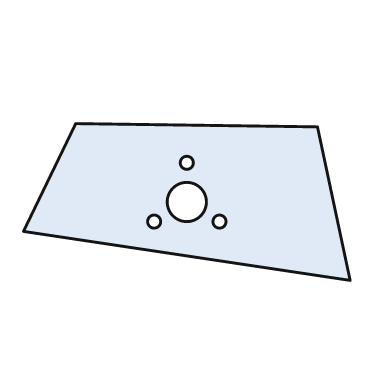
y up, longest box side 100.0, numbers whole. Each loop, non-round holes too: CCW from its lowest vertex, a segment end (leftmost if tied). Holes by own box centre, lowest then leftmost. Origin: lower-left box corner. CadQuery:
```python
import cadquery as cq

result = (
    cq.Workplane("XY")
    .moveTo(100.0, 0.0)
    .lineTo(90.0, 47.0)
    .lineTo(16.0, 48.0)
    .lineTo(0.0, 15.0)
    .close()
    .moveTo(40.0, 18.0)
    .circle(2.0)
    .moveTo(60.0, 18.0)
    .circle(2.0)
    .moveTo(50.0, 24.0)
    .circle(6.0)
    .moveTo(50.0, 36.0)
    .circle(2.0)
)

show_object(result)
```